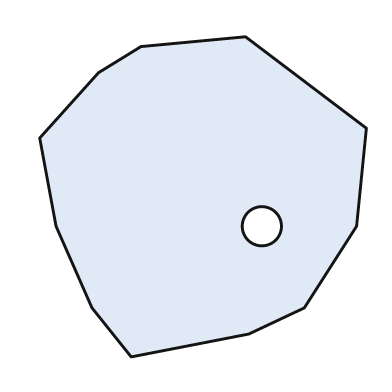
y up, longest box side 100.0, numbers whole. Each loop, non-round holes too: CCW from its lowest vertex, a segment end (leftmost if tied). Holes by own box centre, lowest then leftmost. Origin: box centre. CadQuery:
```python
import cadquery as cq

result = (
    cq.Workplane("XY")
    .moveTo(-22.0, -49.0)
    .lineTo(14.0, -42.0)
    .lineTo(31.0, -34.0)
    .lineTo(47.0, -9.0)
    .lineTo(50.0, 21.0)
    .lineTo(13.0, 49.0)
    .lineTo(-19.0, 46.0)
    .lineTo(-32.0, 38.0)
    .lineTo(-50.0, 18.0)
    .lineTo(-45.0, -9.0)
    .lineTo(-34.0, -34.0)
    .close()
    .moveTo(18.0, -9.0)
    .circle(6.0)
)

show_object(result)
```